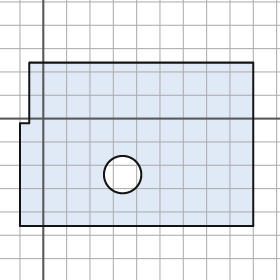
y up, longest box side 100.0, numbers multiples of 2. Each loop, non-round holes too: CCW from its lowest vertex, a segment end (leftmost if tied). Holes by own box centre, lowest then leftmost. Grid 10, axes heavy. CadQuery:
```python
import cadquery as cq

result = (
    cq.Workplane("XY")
    .moveTo(-10.0, -46.0)
    .lineTo(90.0, -46.0)
    .lineTo(90.0, 24.0)
    .lineTo(-6.0, 24.0)
    .lineTo(-6.0, -2.0)
    .lineTo(-10.0, -2.0)
    .close()
    .moveTo(34.0, -24.0)
    .circle(8.0)
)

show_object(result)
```